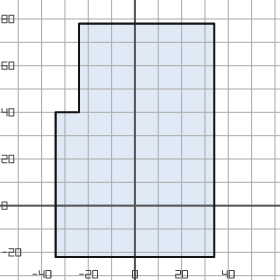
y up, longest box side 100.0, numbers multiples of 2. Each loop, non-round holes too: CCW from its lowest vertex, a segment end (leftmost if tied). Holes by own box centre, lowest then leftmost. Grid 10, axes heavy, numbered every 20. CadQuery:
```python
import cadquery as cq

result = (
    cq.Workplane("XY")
    .moveTo(-34.0, -22.0)
    .lineTo(34.0, -22.0)
    .lineTo(34.0, 78.0)
    .lineTo(-24.0, 78.0)
    .lineTo(-24.0, 40.0)
    .lineTo(-34.0, 40.0)
    .close()
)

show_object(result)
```